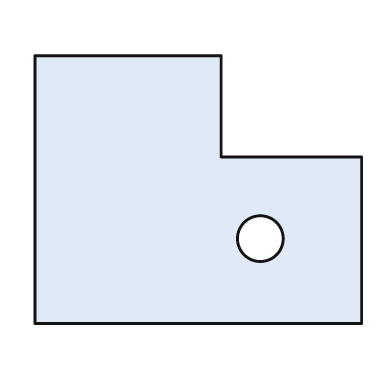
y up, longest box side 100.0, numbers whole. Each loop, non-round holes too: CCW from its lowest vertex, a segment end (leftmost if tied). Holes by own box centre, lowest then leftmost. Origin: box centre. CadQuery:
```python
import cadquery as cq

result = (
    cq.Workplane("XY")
    .moveTo(-50.0, -41.0)
    .lineTo(50.0, -41.0)
    .lineTo(50.0, 10.0)
    .lineTo(7.0, 10.0)
    .lineTo(7.0, 41.0)
    .lineTo(-50.0, 41.0)
    .close()
    .moveTo(19.0, -15.0)
    .circle(7.0)
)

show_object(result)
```